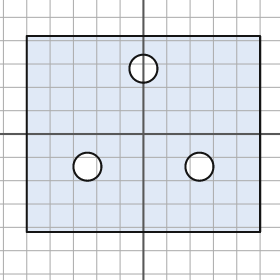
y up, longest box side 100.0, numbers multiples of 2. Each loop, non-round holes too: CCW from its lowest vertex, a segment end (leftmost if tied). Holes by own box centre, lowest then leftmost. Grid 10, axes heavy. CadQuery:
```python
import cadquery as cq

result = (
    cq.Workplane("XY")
    .moveTo(-50.0, -42.0)
    .lineTo(50.0, -42.0)
    .lineTo(50.0, 42.0)
    .lineTo(-50.0, 42.0)
    .close()
    .moveTo(-24.0, -14.0)
    .circle(6.0)
    .moveTo(24.0, -14.0)
    .circle(6.0)
    .moveTo(0.0, 28.0)
    .circle(6.0)
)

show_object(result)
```